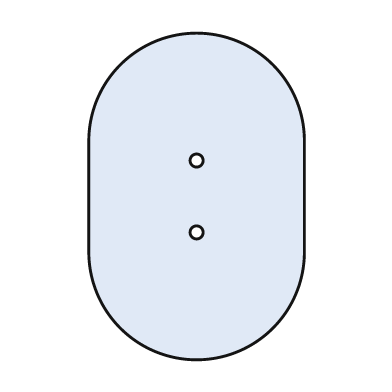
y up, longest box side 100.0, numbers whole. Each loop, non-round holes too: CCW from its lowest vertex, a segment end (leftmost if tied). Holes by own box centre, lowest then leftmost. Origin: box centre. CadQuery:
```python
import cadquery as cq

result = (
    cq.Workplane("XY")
    .moveTo(-33.0, -17.0)
    .threePointArc((0.0, -50.0), (33.0, -17.0))
    .lineTo(33.0, 17.0)
    .threePointArc((0.0, 50.0), (-33.0, 17.0))
    .close()
    .moveTo(0.0, -11.0)
    .circle(2.0)
    .moveTo(0.0, 11.0)
    .circle(2.0)
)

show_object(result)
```